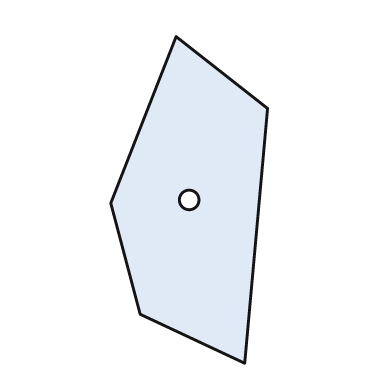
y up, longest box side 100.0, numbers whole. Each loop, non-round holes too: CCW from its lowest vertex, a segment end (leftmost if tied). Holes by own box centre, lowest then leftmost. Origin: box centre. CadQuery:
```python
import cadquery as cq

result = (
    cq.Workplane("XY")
    .moveTo(17.0, -50.0)
    .lineTo(24.0, 28.0)
    .lineTo(-4.0, 50.0)
    .lineTo(-24.0, -1.0)
    .lineTo(-15.0, -35.0)
    .close()
    .moveTo(0.0, 0.0)
    .circle(3.0)
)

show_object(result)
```